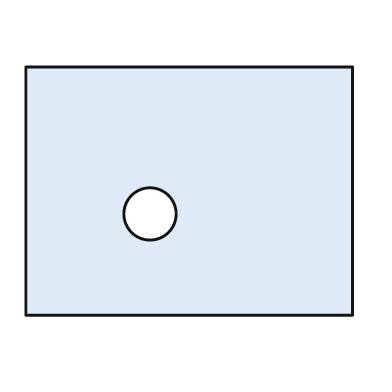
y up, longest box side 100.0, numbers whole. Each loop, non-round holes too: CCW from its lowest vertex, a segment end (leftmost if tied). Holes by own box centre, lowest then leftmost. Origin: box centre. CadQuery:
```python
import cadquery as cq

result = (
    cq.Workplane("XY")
    .moveTo(-50.0, -38.0)
    .lineTo(50.0, -38.0)
    .lineTo(50.0, 38.0)
    .lineTo(-50.0, 38.0)
    .close()
    .moveTo(-12.0, -7.0)
    .circle(8.0)
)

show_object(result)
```